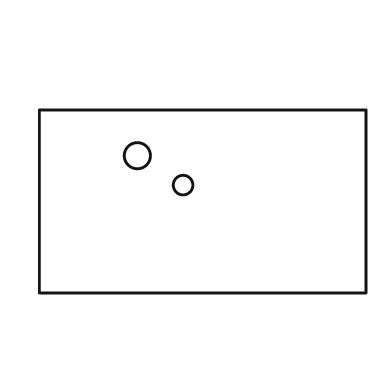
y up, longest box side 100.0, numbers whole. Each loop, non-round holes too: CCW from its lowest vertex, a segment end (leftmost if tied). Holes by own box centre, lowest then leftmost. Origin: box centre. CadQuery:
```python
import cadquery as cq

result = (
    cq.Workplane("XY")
    .moveTo(-50.0, -28.0)
    .lineTo(50.0, -28.0)
    .lineTo(50.0, 28.0)
    .lineTo(-50.0, 28.0)
    .close()
    .moveTo(-6.0, 5.0)
    .circle(3.0)
    .moveTo(-20.0, 14.0)
    .circle(4.0)
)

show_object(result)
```